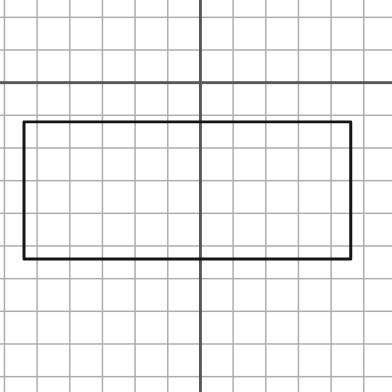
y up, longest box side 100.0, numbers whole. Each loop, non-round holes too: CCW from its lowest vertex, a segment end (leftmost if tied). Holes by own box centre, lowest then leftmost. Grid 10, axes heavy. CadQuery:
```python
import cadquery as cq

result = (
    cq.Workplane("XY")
    .moveTo(-54.0, -54.0)
    .lineTo(46.0, -54.0)
    .lineTo(46.0, -12.0)
    .lineTo(-54.0, -12.0)
    .close()
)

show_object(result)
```